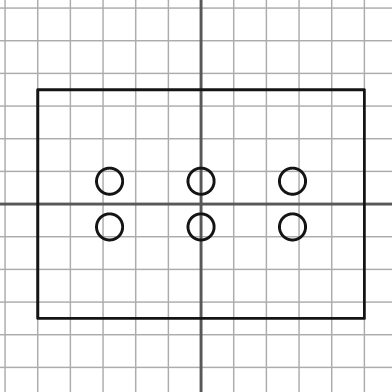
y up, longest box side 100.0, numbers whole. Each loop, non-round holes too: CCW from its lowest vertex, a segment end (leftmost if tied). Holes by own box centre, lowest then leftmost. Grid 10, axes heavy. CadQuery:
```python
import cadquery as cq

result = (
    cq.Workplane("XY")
    .moveTo(-50.0, -35.0)
    .lineTo(50.0, -35.0)
    .lineTo(50.0, 35.0)
    .lineTo(-50.0, 35.0)
    .close()
    .moveTo(-28.0, -7.0)
    .circle(4.0)
    .moveTo(0.0, -7.0)
    .circle(4.0)
    .moveTo(28.0, -7.0)
    .circle(4.0)
    .moveTo(-28.0, 7.0)
    .circle(4.0)
    .moveTo(0.0, 7.0)
    .circle(4.0)
    .moveTo(28.0, 7.0)
    .circle(4.0)
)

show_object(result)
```